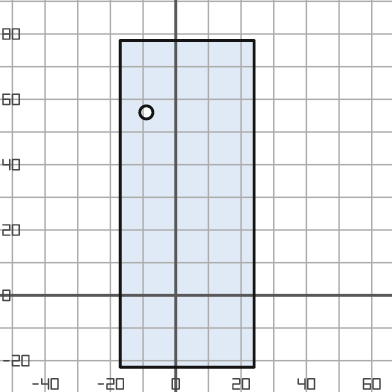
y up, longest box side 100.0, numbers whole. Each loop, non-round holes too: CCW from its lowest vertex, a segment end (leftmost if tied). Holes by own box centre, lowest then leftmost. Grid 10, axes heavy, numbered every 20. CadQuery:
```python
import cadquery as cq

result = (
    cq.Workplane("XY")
    .moveTo(-17.0, -22.0)
    .lineTo(24.0, -22.0)
    .lineTo(24.0, 78.0)
    .lineTo(-17.0, 78.0)
    .close()
    .moveTo(-9.0, 56.0)
    .circle(2.0)
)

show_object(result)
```